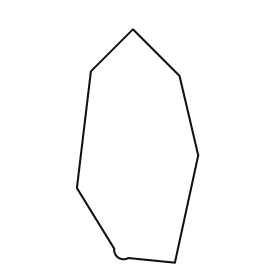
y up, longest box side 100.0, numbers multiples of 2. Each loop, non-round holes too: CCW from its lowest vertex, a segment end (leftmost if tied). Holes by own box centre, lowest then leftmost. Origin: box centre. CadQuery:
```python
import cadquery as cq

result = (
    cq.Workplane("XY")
    .moveTo(16.0, -50.0)
    .lineTo(26.0, -4.0)
    .lineTo(18.0, 30.0)
    .lineTo(-2.0, 50.0)
    .lineTo(-20.0, 32.0)
    .lineTo(-26.0, -18.0)
    .lineTo(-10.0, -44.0)
    .threePointArc((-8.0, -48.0), (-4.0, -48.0))
    .close()
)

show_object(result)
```